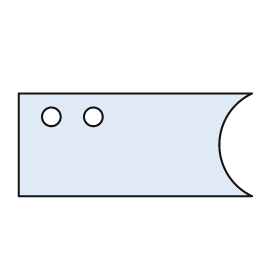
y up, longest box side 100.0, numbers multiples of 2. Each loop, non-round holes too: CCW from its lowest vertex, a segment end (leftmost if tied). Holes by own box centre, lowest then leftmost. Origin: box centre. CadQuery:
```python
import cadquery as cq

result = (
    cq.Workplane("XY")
    .moveTo(-50.0, -22.0)
    .lineTo(50.0, -22.0)
    .threePointArc((36.0, 0.0), (50.0, 22.0))
    .lineTo(-50.0, 22.0)
    .close()
    .moveTo(-36.0, 12.0)
    .circle(4.0)
    .moveTo(-18.0, 12.0)
    .circle(4.0)
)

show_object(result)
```